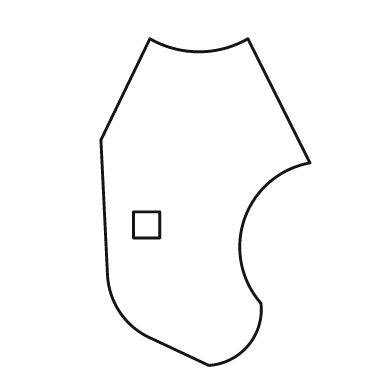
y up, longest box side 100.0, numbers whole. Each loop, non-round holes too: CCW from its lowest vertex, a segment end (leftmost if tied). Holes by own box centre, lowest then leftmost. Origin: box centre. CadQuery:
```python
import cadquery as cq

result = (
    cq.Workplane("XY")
    .moveTo(1.0, -50.0)
    .threePointArc((13.0, -44.0), (17.0, -31.0))
    .threePointArc((12.0, -5.0), (32.0, 12.0))
    .lineTo(13.0, 50.0)
    .threePointArc((-2.0, 46.0), (-17.0, 50.0))
    .lineTo(-32.0, 19.0)
    .lineTo(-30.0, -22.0)
    .threePointArc((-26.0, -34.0), (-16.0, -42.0))
    .close()
    .moveTo(-22.0, -11.0)
    .lineTo(-14.0, -11.0)
    .lineTo(-14.0, -3.0)
    .lineTo(-22.0, -3.0)
    .close()
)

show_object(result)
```